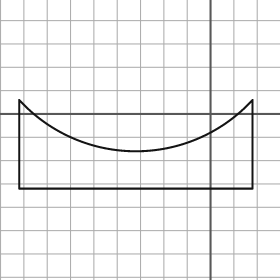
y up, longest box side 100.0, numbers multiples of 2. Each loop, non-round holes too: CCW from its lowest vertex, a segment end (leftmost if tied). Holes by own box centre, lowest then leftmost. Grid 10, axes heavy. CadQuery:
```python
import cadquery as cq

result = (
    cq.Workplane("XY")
    .moveTo(-82.0, -32.0)
    .lineTo(18.0, -32.0)
    .lineTo(18.0, 6.0)
    .threePointArc((-32.0, -16.0), (-82.0, 6.0))
    .close()
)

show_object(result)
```